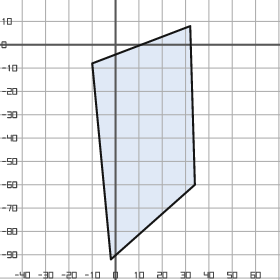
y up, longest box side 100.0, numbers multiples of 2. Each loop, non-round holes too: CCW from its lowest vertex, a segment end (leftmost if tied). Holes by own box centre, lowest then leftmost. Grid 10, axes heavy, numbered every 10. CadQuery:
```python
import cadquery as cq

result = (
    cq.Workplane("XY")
    .moveTo(-2.0, -92.0)
    .lineTo(34.0, -60.0)
    .lineTo(32.0, 8.0)
    .lineTo(-10.0, -8.0)
    .close()
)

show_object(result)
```